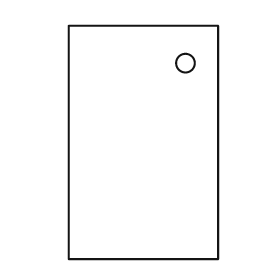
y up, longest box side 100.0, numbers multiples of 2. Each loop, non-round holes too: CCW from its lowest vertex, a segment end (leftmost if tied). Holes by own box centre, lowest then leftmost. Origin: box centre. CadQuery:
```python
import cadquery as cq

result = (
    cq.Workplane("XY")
    .moveTo(-32.0, -50.0)
    .lineTo(32.0, -50.0)
    .lineTo(32.0, 50.0)
    .lineTo(-32.0, 50.0)
    .close()
    .moveTo(18.0, 34.0)
    .circle(4.0)
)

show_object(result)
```